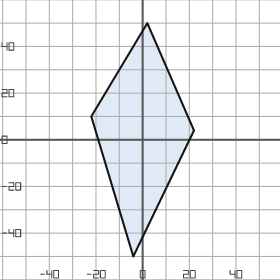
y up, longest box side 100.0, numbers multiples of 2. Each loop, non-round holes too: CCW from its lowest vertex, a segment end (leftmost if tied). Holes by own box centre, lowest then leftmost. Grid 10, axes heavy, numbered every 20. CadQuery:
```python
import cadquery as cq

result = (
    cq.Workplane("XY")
    .moveTo(-4.0, -50.0)
    .lineTo(22.0, 4.0)
    .lineTo(2.0, 50.0)
    .lineTo(-22.0, 10.0)
    .close()
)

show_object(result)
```